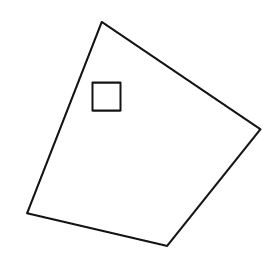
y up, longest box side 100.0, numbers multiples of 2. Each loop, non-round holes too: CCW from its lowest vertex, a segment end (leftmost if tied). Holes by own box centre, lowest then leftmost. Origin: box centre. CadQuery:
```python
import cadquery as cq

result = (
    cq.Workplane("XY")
    .moveTo(10.0, -48.0)
    .lineTo(50.0, 2.0)
    .lineTo(-18.0, 48.0)
    .lineTo(-50.0, -34.0)
    .close()
    .moveTo(-22.0, 10.0)
    .lineTo(-10.0, 10.0)
    .lineTo(-10.0, 22.0)
    .lineTo(-22.0, 22.0)
    .close()
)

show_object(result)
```